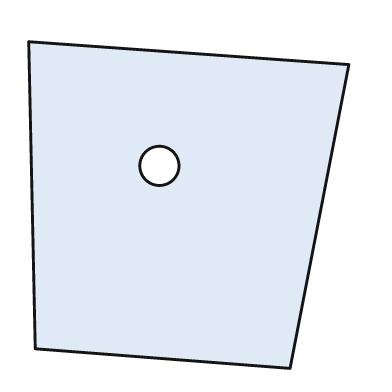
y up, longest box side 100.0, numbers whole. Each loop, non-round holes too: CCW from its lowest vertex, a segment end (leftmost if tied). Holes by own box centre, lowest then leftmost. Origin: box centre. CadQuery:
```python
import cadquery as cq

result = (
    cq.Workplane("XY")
    .moveTo(31.0, -50.0)
    .lineTo(49.0, 43.0)
    .lineTo(-49.0, 50.0)
    .lineTo(-47.0, -44.0)
    .close()
    .moveTo(-9.0, 12.0)
    .circle(6.0)
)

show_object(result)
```